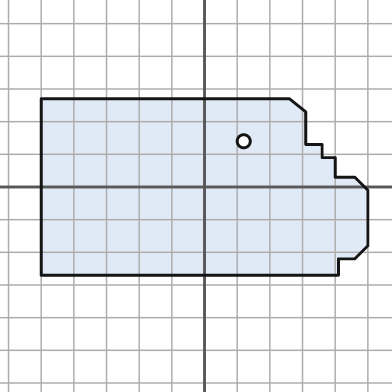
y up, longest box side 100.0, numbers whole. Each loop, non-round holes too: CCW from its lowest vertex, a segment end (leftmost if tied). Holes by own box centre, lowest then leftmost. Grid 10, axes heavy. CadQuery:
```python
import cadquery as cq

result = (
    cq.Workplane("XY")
    .moveTo(-50.0, -27.0)
    .lineTo(41.0, -27.0)
    .lineTo(41.0, -22.0)
    .lineTo(46.0, -22.0)
    .lineTo(50.0, -18.0)
    .lineTo(50.0, -1.0)
    .lineTo(46.0, 3.0)
    .lineTo(40.0, 3.0)
    .lineTo(40.0, 9.0)
    .lineTo(36.0, 9.0)
    .lineTo(36.0, 13.0)
    .lineTo(31.0, 13.0)
    .lineTo(31.0, 23.0)
    .lineTo(26.0, 27.0)
    .lineTo(-50.0, 27.0)
    .close()
    .moveTo(12.0, 14.0)
    .circle(2.0)
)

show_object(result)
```